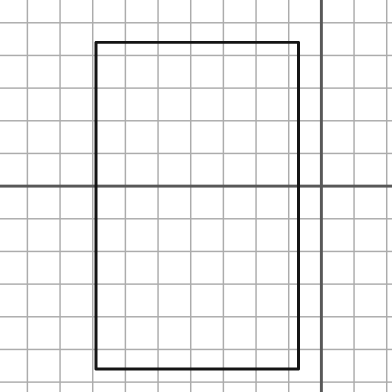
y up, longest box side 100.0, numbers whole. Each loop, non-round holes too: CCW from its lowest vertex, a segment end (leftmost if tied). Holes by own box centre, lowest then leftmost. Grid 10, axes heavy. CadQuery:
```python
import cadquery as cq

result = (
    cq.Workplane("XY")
    .moveTo(-69.0, -56.0)
    .lineTo(-7.0, -56.0)
    .lineTo(-7.0, 44.0)
    .lineTo(-69.0, 44.0)
    .close()
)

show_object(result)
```